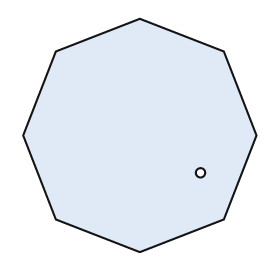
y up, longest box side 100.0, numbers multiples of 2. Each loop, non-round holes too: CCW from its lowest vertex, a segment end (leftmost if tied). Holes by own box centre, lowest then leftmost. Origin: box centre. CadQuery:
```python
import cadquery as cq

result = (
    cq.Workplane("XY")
    .moveTo(0.0, -50.0)
    .lineTo(36.0, -36.0)
    .lineTo(50.0, 0.0)
    .lineTo(36.0, 36.0)
    .lineTo(0.0, 50.0)
    .lineTo(-36.0, 36.0)
    .lineTo(-50.0, 0.0)
    .lineTo(-36.0, -36.0)
    .close()
    .moveTo(26.0, -16.0)
    .circle(2.0)
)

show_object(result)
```